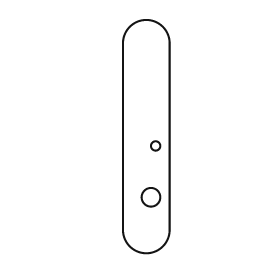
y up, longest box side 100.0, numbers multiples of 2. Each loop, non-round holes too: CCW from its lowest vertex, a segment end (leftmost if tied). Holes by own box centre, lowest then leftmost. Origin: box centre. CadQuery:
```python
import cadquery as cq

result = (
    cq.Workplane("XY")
    .moveTo(-10.0, -40.0)
    .threePointArc((0.0, -50.0), (10.0, -40.0))
    .lineTo(10.0, 40.0)
    .threePointArc((0.0, 50.0), (-10.0, 40.0))
    .close()
    .moveTo(2.0, -26.0)
    .circle(4.0)
    .moveTo(4.0, -4.0)
    .circle(2.0)
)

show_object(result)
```